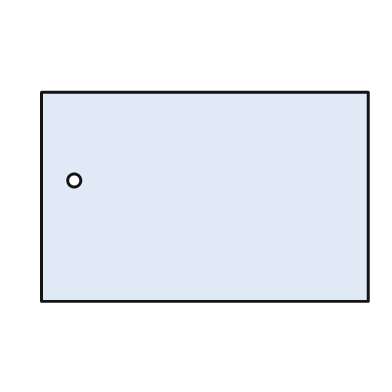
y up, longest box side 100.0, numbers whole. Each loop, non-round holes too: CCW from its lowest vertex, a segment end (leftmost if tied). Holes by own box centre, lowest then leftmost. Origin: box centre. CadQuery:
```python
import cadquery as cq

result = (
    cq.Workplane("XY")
    .moveTo(-50.0, -32.0)
    .lineTo(50.0, -32.0)
    .lineTo(50.0, 32.0)
    .lineTo(-50.0, 32.0)
    .close()
    .moveTo(-40.0, 5.0)
    .circle(2.0)
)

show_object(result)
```